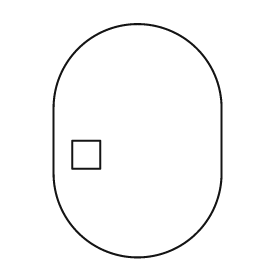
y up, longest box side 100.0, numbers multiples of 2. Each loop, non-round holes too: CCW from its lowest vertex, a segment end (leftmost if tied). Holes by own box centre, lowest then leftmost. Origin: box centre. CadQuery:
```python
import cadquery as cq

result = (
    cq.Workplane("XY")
    .moveTo(-36.0, -14.0)
    .threePointArc((0.0, -50.0), (36.0, -14.0))
    .lineTo(36.0, 14.0)
    .threePointArc((0.0, 50.0), (-36.0, 14.0))
    .close()
    .moveTo(-28.0, -12.0)
    .lineTo(-16.0, -12.0)
    .lineTo(-16.0, 0.0)
    .lineTo(-28.0, 0.0)
    .close()
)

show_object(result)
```